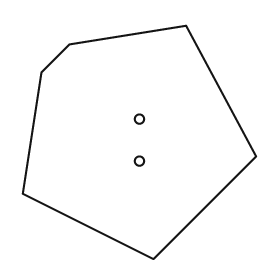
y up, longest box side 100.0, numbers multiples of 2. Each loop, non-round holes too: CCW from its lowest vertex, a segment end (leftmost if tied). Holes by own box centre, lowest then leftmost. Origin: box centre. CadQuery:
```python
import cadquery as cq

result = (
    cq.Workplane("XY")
    .moveTo(6.0, -50.0)
    .lineTo(50.0, -6.0)
    .lineTo(20.0, 50.0)
    .lineTo(-30.0, 42.0)
    .lineTo(-42.0, 30.0)
    .lineTo(-50.0, -22.0)
    .close()
    .moveTo(0.0, -8.0)
    .circle(2.0)
    .moveTo(0.0, 10.0)
    .circle(2.0)
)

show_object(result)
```